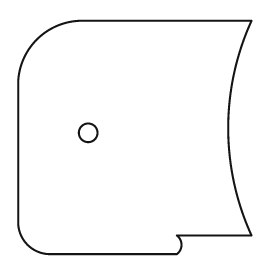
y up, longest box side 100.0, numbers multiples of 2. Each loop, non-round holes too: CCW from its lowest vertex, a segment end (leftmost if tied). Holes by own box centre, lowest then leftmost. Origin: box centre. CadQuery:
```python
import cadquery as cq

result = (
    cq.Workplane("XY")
    .moveTo(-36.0, -50.0)
    .lineTo(18.0, -50.0)
    .threePointArc((20.0, -46.0), (18.0, -42.0))
    .lineTo(50.0, -42.0)
    .threePointArc((40.0, 4.0), (50.0, 50.0))
    .lineTo(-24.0, 50.0)
    .threePointArc((-42.0, 42.0), (-50.0, 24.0))
    .lineTo(-50.0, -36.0)
    .threePointArc((-46.0, -46.0), (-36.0, -50.0))
    .close()
    .moveTo(-20.0, 2.0)
    .circle(4.0)
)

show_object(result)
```